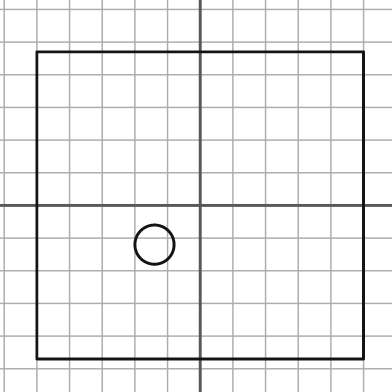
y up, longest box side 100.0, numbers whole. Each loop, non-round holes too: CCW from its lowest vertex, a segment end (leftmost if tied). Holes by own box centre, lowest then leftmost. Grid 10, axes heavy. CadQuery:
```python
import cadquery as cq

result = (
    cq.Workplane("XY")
    .moveTo(-50.0, -47.0)
    .lineTo(50.0, -47.0)
    .lineTo(50.0, 47.0)
    .lineTo(-50.0, 47.0)
    .close()
    .moveTo(-14.0, -12.0)
    .circle(6.0)
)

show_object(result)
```